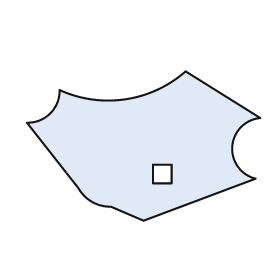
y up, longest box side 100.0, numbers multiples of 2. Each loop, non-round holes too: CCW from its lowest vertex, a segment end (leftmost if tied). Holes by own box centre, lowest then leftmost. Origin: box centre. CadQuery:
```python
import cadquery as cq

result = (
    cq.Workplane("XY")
    .moveTo(0.0, -32.0)
    .lineTo(48.0, -14.0)
    .threePointArc((38.0, 0.0), (50.0, 12.0))
    .lineTo(18.0, 32.0)
    .threePointArc((-8.0, 20.0), (-36.0, 24.0))
    .threePointArc((-40.0, 14.0), (-50.0, 10.0))
    .lineTo(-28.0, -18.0)
    .threePointArc((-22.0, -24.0), (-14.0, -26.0))
    .close()
    .moveTo(4.0, -16.0)
    .lineTo(12.0, -16.0)
    .lineTo(12.0, -8.0)
    .lineTo(4.0, -8.0)
    .close()
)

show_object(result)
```